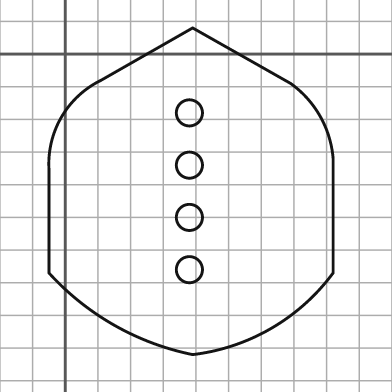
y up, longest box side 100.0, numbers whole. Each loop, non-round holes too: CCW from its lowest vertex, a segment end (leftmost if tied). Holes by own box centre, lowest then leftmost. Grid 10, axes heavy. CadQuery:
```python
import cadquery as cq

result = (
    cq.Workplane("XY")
    .moveTo(39.0, -92.0)
    .threePointArc((63.0, -84.0), (82.0, -67.0))
    .lineTo(82.0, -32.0)
    .threePointArc((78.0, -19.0), (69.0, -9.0))
    .lineTo(39.0, 8.0)
    .lineTo(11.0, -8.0)
    .threePointArc((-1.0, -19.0), (-5.0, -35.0))
    .lineTo(-5.0, -67.0)
    .threePointArc((15.0, -83.0), (39.0, -92.0))
    .close()
    .moveTo(38.0, -66.0)
    .circle(4.0)
    .moveTo(38.0, -50.0)
    .circle(4.0)
    .moveTo(38.0, -34.0)
    .circle(4.0)
    .moveTo(38.0, -18.0)
    .circle(4.0)
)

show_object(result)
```